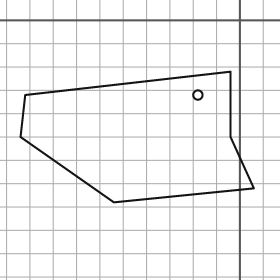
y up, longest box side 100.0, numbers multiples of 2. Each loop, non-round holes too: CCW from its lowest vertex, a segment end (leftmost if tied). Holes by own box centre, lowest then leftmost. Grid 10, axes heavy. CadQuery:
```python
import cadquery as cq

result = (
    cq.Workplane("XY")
    .moveTo(-54.0, -78.0)
    .lineTo(6.0, -72.0)
    .lineTo(-4.0, -50.0)
    .lineTo(-4.0, -22.0)
    .lineTo(-92.0, -32.0)
    .lineTo(-94.0, -50.0)
    .close()
    .moveTo(-18.0, -32.0)
    .circle(2.0)
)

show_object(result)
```